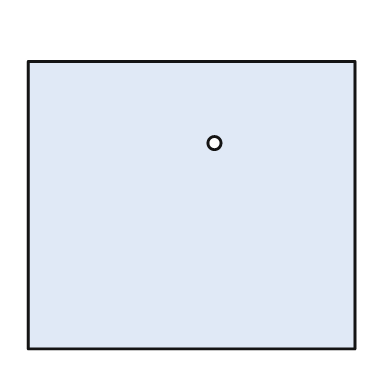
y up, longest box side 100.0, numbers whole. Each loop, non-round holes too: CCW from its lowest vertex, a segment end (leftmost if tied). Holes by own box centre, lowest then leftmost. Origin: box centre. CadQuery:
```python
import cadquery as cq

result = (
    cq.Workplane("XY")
    .moveTo(-50.0, -44.0)
    .lineTo(50.0, -44.0)
    .lineTo(50.0, 44.0)
    .lineTo(-50.0, 44.0)
    .close()
    .moveTo(7.0, 19.0)
    .circle(2.0)
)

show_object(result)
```